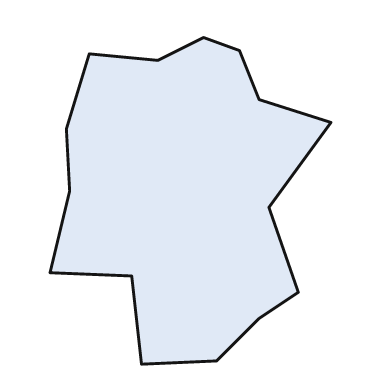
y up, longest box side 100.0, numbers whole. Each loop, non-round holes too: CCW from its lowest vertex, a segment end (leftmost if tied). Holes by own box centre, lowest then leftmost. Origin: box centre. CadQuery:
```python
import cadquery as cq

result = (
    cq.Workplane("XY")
    .moveTo(-15.0, -50.0)
    .lineTo(8.0, -49.0)
    .lineTo(21.0, -36.0)
    .lineTo(33.0, -28.0)
    .lineTo(24.0, -2.0)
    .lineTo(43.0, 24.0)
    .lineTo(21.0, 31.0)
    .lineTo(15.0, 46.0)
    .lineTo(4.0, 50.0)
    .lineTo(-10.0, 43.0)
    .lineTo(-31.0, 45.0)
    .lineTo(-38.0, 22.0)
    .lineTo(-37.0, 3.0)
    .lineTo(-43.0, -22.0)
    .lineTo(-18.0, -23.0)
    .close()
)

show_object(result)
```